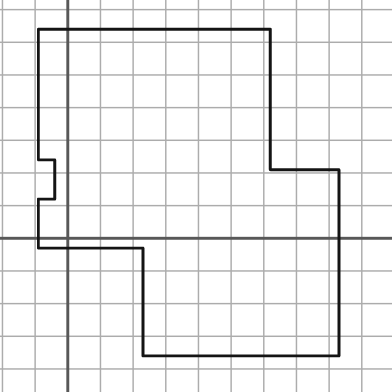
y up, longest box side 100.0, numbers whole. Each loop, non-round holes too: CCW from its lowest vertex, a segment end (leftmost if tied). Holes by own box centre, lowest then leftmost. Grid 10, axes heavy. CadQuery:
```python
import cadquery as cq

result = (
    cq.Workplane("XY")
    .moveTo(23.0, -36.0)
    .lineTo(83.0, -36.0)
    .lineTo(83.0, 21.0)
    .lineTo(62.0, 21.0)
    .lineTo(62.0, 64.0)
    .lineTo(-9.0, 64.0)
    .lineTo(-9.0, 24.0)
    .lineTo(-4.0, 24.0)
    .lineTo(-4.0, 12.0)
    .lineTo(-9.0, 12.0)
    .lineTo(-9.0, -3.0)
    .lineTo(23.0, -3.0)
    .close()
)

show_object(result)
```